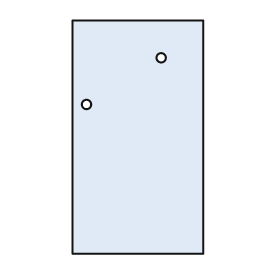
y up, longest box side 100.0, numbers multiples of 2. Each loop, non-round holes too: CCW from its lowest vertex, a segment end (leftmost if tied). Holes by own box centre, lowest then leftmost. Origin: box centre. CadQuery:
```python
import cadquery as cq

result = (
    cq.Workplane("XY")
    .moveTo(-28.0, -50.0)
    .lineTo(28.0, -50.0)
    .lineTo(28.0, 50.0)
    .lineTo(-28.0, 50.0)
    .close()
    .moveTo(-22.0, 14.0)
    .circle(2.0)
    .moveTo(10.0, 34.0)
    .circle(2.0)
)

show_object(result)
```